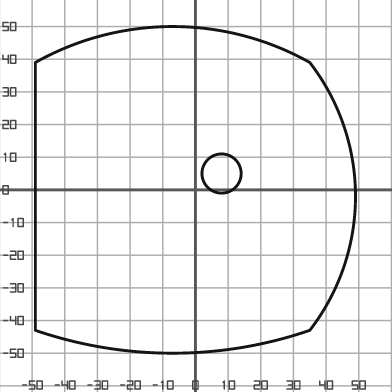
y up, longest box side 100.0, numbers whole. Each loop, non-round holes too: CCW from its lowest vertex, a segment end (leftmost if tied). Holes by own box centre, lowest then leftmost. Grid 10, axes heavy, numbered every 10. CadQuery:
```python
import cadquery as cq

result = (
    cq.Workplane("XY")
    .moveTo(-49.0, -43.0)
    .threePointArc((-7.0, -50.0), (35.0, -43.0))
    .threePointArc((49.0, -2.0), (35.0, 39.0))
    .threePointArc((-7.0, 50.0), (-49.0, 39.0))
    .close()
    .moveTo(8.0, 5.0)
    .circle(6.0)
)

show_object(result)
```